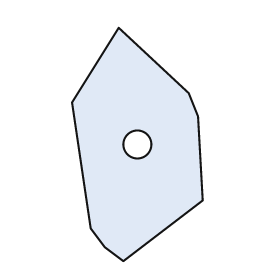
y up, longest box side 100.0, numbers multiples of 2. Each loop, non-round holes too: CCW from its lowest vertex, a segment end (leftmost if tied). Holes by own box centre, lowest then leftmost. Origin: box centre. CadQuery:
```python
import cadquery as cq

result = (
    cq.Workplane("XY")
    .moveTo(-6.0, -50.0)
    .lineTo(28.0, -24.0)
    .lineTo(26.0, 12.0)
    .lineTo(22.0, 22.0)
    .lineTo(-8.0, 50.0)
    .lineTo(-28.0, 18.0)
    .lineTo(-20.0, -36.0)
    .lineTo(-14.0, -44.0)
    .close()
    .moveTo(0.0, 0.0)
    .circle(6.0)
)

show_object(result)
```